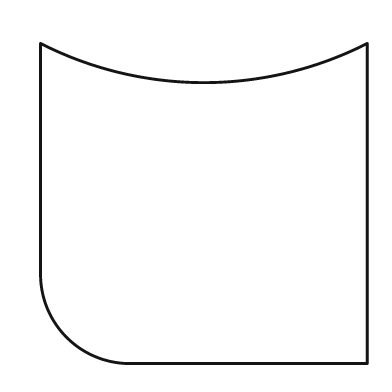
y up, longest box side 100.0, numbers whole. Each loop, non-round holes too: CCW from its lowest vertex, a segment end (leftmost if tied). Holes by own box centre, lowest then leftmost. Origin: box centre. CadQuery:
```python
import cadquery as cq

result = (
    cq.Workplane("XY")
    .moveTo(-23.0, -49.0)
    .lineTo(50.0, -49.0)
    .lineTo(50.0, 49.0)
    .threePointArc((0.0, 37.0), (-50.0, 49.0))
    .lineTo(-50.0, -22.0)
    .threePointArc((-42.0, -41.0), (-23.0, -49.0))
    .close()
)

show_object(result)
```